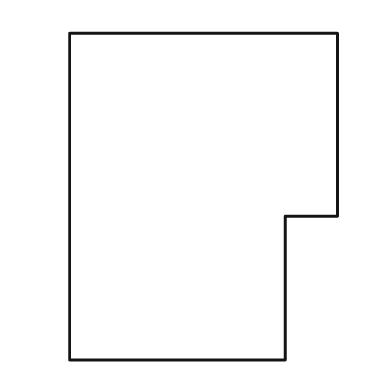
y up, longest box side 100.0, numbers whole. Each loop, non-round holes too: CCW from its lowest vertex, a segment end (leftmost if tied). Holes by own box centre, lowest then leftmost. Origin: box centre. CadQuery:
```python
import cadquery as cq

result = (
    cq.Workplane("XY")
    .moveTo(-41.0, -50.0)
    .lineTo(25.0, -50.0)
    .lineTo(25.0, -6.0)
    .lineTo(41.0, -6.0)
    .lineTo(41.0, 50.0)
    .lineTo(-41.0, 50.0)
    .close()
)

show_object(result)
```